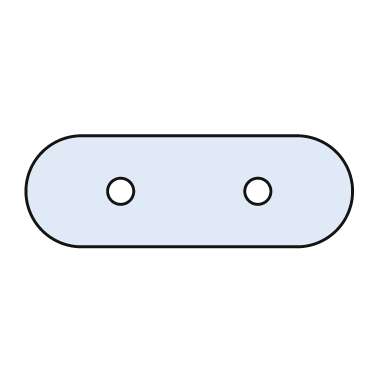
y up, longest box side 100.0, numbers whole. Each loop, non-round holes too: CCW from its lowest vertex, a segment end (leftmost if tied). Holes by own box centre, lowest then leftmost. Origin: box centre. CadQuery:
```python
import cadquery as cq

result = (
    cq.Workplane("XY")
    .moveTo(-33.0, -17.0)
    .lineTo(33.0, -17.0)
    .threePointArc((50.0, 0.0), (33.0, 17.0))
    .lineTo(-33.0, 17.0)
    .threePointArc((-50.0, 0.0), (-33.0, -17.0))
    .close()
    .moveTo(-21.0, 0.0)
    .circle(4.0)
    .moveTo(21.0, 0.0)
    .circle(4.0)
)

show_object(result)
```